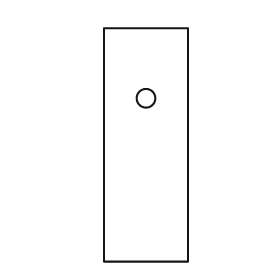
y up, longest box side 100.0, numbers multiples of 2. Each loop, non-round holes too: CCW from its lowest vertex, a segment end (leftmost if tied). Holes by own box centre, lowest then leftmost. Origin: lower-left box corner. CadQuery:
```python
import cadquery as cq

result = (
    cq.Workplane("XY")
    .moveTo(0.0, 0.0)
    .lineTo(36.0, 0.0)
    .lineTo(36.0, 100.0)
    .lineTo(0.0, 100.0)
    .close()
    .moveTo(18.0, 70.0)
    .circle(4.0)
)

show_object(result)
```